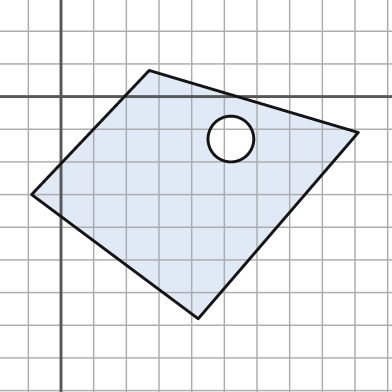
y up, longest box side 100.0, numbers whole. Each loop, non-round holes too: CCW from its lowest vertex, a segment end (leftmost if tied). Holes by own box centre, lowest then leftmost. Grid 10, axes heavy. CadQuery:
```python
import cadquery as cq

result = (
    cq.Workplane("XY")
    .moveTo(42.0, -68.0)
    .lineTo(91.0, -11.0)
    .lineTo(27.0, 8.0)
    .lineTo(-9.0, -30.0)
    .close()
    .moveTo(52.0, -13.0)
    .circle(7.0)
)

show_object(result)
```